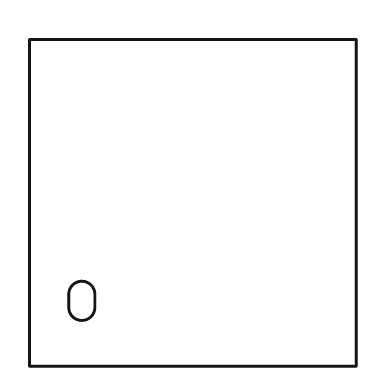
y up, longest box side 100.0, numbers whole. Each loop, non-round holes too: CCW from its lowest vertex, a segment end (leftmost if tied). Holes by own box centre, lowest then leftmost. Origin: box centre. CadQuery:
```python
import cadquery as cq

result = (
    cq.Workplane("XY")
    .moveTo(-50.0, -50.0)
    .lineTo(50.0, -50.0)
    .lineTo(50.0, 50.0)
    .lineTo(-50.0, 50.0)
    .close()
    .moveTo(-38.0, -32.0)
    .threePointArc((-34.0, -36.0), (-30.0, -32.0))
    .lineTo(-30.0, -28.0)
    .threePointArc((-34.0, -24.0), (-38.0, -28.0))
    .close()
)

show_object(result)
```